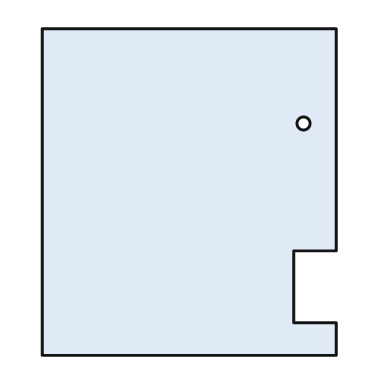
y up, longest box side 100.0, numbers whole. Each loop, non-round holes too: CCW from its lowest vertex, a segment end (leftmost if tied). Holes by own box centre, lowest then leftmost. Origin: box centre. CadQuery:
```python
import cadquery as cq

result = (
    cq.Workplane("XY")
    .moveTo(-45.0, -50.0)
    .lineTo(45.0, -50.0)
    .lineTo(45.0, -40.0)
    .lineTo(32.0, -40.0)
    .lineTo(32.0, -18.0)
    .lineTo(45.0, -18.0)
    .lineTo(45.0, 50.0)
    .lineTo(-45.0, 50.0)
    .close()
    .moveTo(35.0, 21.0)
    .circle(2.0)
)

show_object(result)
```